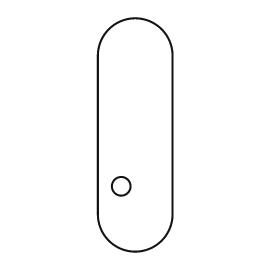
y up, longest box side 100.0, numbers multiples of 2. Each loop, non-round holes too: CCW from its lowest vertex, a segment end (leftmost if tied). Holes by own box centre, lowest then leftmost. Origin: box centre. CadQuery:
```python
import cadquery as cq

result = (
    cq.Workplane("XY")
    .moveTo(-16.0, -34.0)
    .threePointArc((0.0, -50.0), (16.0, -34.0))
    .lineTo(16.0, 34.0)
    .threePointArc((0.0, 50.0), (-16.0, 34.0))
    .close()
    .moveTo(-6.0, -22.0)
    .circle(4.0)
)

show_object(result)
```